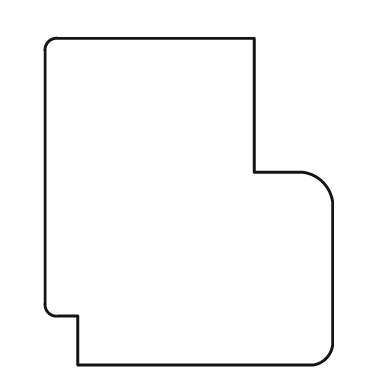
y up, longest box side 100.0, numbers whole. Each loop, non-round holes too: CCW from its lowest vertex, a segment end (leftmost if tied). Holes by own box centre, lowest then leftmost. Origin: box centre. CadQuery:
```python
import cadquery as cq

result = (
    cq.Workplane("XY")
    .moveTo(-34.0, -50.0)
    .lineTo(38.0, -50.0)
    .threePointArc((42.0, -48.0), (44.0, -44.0))
    .lineTo(44.0, 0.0)
    .threePointArc((41.0, 6.0), (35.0, 9.0))
    .lineTo(20.0, 9.0)
    .lineTo(20.0, 50.0)
    .lineTo(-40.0, 50.0)
    .threePointArc((-43.0, 49.0), (-44.0, 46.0))
    .lineTo(-44.0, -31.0)
    .threePointArc((-43.0, -34.0), (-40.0, -35.0))
    .lineTo(-34.0, -35.0)
    .close()
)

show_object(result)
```